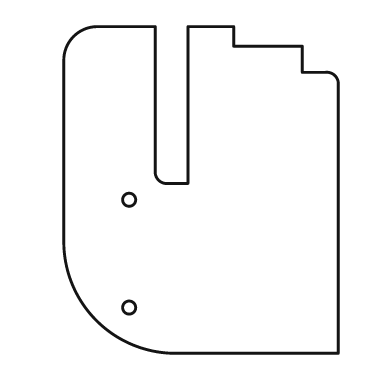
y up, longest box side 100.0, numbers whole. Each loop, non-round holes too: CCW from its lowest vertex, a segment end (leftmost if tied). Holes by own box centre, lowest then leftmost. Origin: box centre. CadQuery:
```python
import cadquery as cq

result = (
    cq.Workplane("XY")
    .moveTo(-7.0, -50.0)
    .lineTo(42.0, -50.0)
    .lineTo(42.0, 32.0)
    .threePointArc((41.0, 35.0), (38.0, 36.0))
    .lineTo(31.0, 36.0)
    .lineTo(31.0, 44.0)
    .lineTo(10.0, 44.0)
    .lineTo(10.0, 50.0)
    .lineTo(-4.0, 50.0)
    .lineTo(-4.0, 2.0)
    .lineTo(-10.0, 2.0)
    .threePointArc((-13.0, 3.0), (-14.0, 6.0))
    .lineTo(-14.0, 50.0)
    .lineTo(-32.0, 50.0)
    .threePointArc((-39.0, 47.0), (-42.0, 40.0))
    .lineTo(-42.0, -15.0)
    .threePointArc((-32.0, -40.0), (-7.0, -50.0))
    .close()
    .moveTo(-22.0, -36.0)
    .circle(2.0)
    .moveTo(-22.0, -3.0)
    .circle(2.0)
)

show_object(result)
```